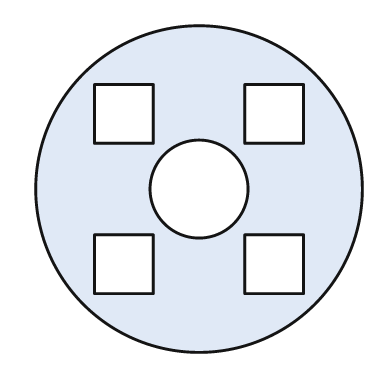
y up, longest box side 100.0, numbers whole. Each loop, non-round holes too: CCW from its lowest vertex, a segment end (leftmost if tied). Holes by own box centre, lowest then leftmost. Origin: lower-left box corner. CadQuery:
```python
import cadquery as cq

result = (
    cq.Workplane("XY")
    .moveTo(50.0, 50.0)
    .circle(50.0)
    .moveTo(18.0, 18.0)
    .lineTo(36.0, 18.0)
    .lineTo(36.0, 36.0)
    .lineTo(18.0, 36.0)
    .close()
    .moveTo(64.0, 18.0)
    .lineTo(82.0, 18.0)
    .lineTo(82.0, 36.0)
    .lineTo(64.0, 36.0)
    .close()
    .moveTo(50.0, 50.0)
    .circle(15.0)
    .moveTo(18.0, 64.0)
    .lineTo(36.0, 64.0)
    .lineTo(36.0, 82.0)
    .lineTo(18.0, 82.0)
    .close()
    .moveTo(64.0, 64.0)
    .lineTo(82.0, 64.0)
    .lineTo(82.0, 82.0)
    .lineTo(64.0, 82.0)
    .close()
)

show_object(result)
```